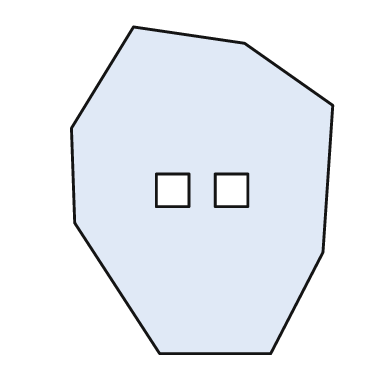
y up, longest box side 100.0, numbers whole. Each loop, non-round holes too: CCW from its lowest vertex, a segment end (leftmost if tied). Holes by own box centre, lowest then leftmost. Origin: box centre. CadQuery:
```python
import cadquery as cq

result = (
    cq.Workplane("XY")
    .moveTo(-13.0, -50.0)
    .lineTo(21.0, -50.0)
    .lineTo(37.0, -19.0)
    .lineTo(40.0, 26.0)
    .lineTo(13.0, 45.0)
    .lineTo(-21.0, 50.0)
    .lineTo(-40.0, 19.0)
    .lineTo(-39.0, -10.0)
    .close()
    .moveTo(-14.0, -5.0)
    .lineTo(-4.0, -5.0)
    .lineTo(-4.0, 5.0)
    .lineTo(-14.0, 5.0)
    .close()
    .moveTo(4.0, -5.0)
    .lineTo(14.0, -5.0)
    .lineTo(14.0, 5.0)
    .lineTo(4.0, 5.0)
    .close()
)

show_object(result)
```